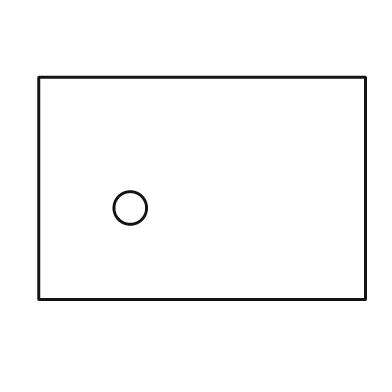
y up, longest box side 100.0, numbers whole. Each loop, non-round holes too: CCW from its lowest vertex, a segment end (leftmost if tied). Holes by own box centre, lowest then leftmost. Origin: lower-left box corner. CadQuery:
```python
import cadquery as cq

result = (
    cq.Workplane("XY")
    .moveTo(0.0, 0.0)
    .lineTo(100.0, 0.0)
    .lineTo(100.0, 68.0)
    .lineTo(0.0, 68.0)
    .close()
    .moveTo(28.0, 28.0)
    .circle(5.0)
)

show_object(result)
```